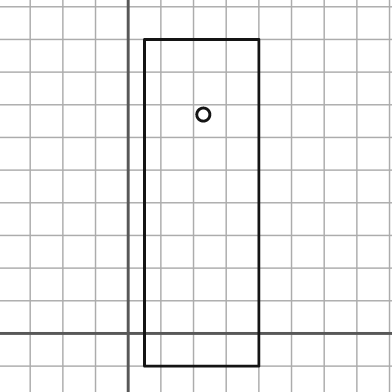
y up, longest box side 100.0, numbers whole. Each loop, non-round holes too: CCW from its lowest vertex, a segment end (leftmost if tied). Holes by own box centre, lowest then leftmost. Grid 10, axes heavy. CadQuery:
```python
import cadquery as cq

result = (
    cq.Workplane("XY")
    .moveTo(5.0, -10.0)
    .lineTo(40.0, -10.0)
    .lineTo(40.0, 90.0)
    .lineTo(5.0, 90.0)
    .close()
    .moveTo(23.0, 67.0)
    .circle(2.0)
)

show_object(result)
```